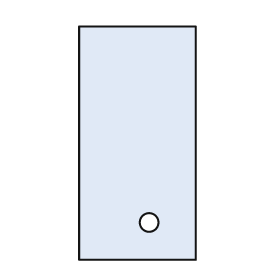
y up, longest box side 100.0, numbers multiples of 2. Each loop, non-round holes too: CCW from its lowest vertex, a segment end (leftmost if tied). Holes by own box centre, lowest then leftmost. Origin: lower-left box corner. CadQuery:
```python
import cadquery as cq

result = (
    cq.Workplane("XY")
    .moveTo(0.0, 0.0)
    .lineTo(50.0, 0.0)
    .lineTo(50.0, 100.0)
    .lineTo(0.0, 100.0)
    .close()
    .moveTo(30.0, 16.0)
    .circle(4.0)
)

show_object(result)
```